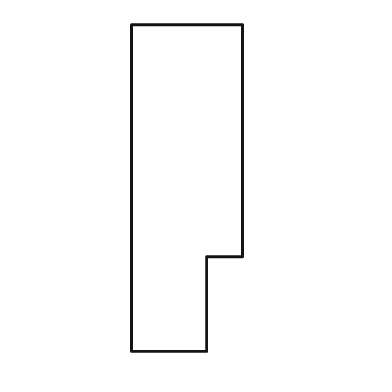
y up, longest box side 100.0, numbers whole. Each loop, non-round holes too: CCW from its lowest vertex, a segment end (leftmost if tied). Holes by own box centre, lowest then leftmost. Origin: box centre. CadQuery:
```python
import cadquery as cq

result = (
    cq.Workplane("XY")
    .moveTo(-17.0, -50.0)
    .lineTo(6.0, -50.0)
    .lineTo(6.0, -21.0)
    .lineTo(17.0, -21.0)
    .lineTo(17.0, 50.0)
    .lineTo(-17.0, 50.0)
    .close()
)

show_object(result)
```